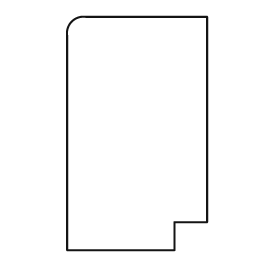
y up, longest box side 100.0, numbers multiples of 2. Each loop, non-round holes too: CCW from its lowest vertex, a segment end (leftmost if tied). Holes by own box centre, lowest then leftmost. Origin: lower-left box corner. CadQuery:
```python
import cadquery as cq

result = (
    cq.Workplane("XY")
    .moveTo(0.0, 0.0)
    .lineTo(46.0, 0.0)
    .lineTo(46.0, 12.0)
    .lineTo(60.0, 12.0)
    .lineTo(60.0, 100.0)
    .lineTo(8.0, 100.0)
    .threePointArc((2.0, 98.0), (0.0, 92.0))
    .close()
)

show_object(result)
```